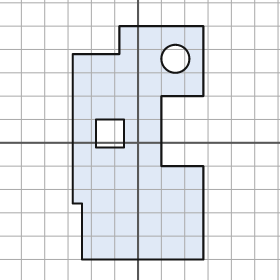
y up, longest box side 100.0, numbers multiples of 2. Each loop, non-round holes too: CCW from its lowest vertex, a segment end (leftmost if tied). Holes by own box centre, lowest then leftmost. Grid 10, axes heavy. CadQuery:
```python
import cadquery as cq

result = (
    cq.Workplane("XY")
    .moveTo(-24.0, -50.0)
    .lineTo(28.0, -50.0)
    .lineTo(28.0, -10.0)
    .lineTo(10.0, -10.0)
    .lineTo(10.0, 20.0)
    .lineTo(28.0, 20.0)
    .lineTo(28.0, 50.0)
    .lineTo(-8.0, 50.0)
    .lineTo(-8.0, 38.0)
    .lineTo(-28.0, 38.0)
    .lineTo(-28.0, -26.0)
    .lineTo(-24.0, -26.0)
    .close()
    .moveTo(-18.0, -2.0)
    .lineTo(-6.0, -2.0)
    .lineTo(-6.0, 10.0)
    .lineTo(-18.0, 10.0)
    .close()
    .moveTo(16.0, 36.0)
    .circle(6.0)
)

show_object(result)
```